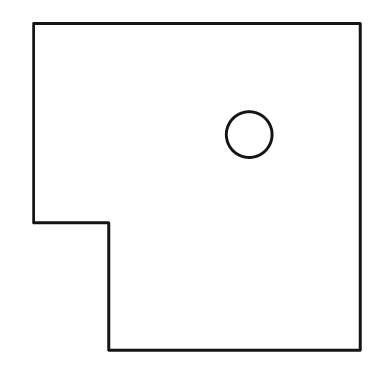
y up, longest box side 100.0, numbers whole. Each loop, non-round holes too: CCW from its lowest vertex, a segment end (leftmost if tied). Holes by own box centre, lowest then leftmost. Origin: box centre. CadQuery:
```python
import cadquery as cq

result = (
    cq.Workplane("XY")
    .moveTo(-27.0, -50.0)
    .lineTo(50.0, -50.0)
    .lineTo(50.0, 50.0)
    .lineTo(-50.0, 50.0)
    .lineTo(-50.0, -11.0)
    .lineTo(-27.0, -11.0)
    .close()
    .moveTo(16.0, 16.0)
    .circle(7.0)
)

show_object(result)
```